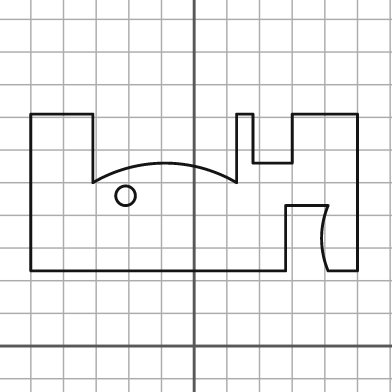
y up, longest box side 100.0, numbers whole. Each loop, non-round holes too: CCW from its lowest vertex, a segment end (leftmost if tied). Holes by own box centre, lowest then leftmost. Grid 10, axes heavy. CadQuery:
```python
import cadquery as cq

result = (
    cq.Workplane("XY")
    .moveTo(-50.0, 23.0)
    .lineTo(28.0, 23.0)
    .lineTo(28.0, 43.0)
    .lineTo(41.0, 43.0)
    .threePointArc((39.0, 33.0), (41.0, 23.0))
    .lineTo(50.0, 23.0)
    .lineTo(50.0, 71.0)
    .lineTo(30.0, 71.0)
    .lineTo(30.0, 56.0)
    .lineTo(18.0, 56.0)
    .lineTo(18.0, 71.0)
    .lineTo(13.0, 71.0)
    .lineTo(13.0, 50.0)
    .threePointArc((-9.0, 56.0), (-31.0, 50.0))
    .lineTo(-31.0, 71.0)
    .lineTo(-50.0, 71.0)
    .close()
    .moveTo(-21.0, 46.0)
    .circle(3.0)
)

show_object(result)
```